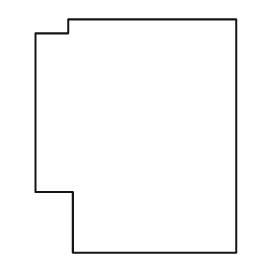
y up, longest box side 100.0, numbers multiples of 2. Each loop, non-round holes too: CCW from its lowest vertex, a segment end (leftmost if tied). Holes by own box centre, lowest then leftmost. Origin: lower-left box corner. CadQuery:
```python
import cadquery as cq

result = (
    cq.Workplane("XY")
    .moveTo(16.0, 0.0)
    .lineTo(86.0, 0.0)
    .lineTo(86.0, 100.0)
    .lineTo(14.0, 100.0)
    .lineTo(14.0, 94.0)
    .lineTo(0.0, 94.0)
    .lineTo(0.0, 26.0)
    .lineTo(16.0, 26.0)
    .close()
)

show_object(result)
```